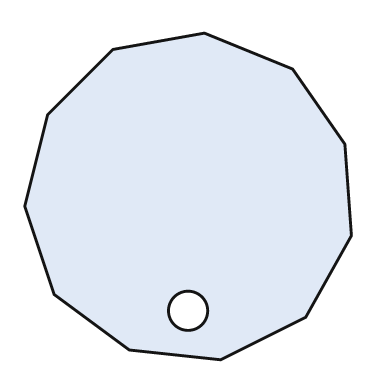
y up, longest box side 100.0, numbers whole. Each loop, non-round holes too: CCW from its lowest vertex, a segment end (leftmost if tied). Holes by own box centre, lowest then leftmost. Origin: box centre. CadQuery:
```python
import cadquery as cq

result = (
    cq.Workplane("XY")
    .moveTo(10.0, -50.0)
    .lineTo(36.0, -37.0)
    .lineTo(50.0, -12.0)
    .lineTo(48.0, 16.0)
    .lineTo(32.0, 39.0)
    .lineTo(5.0, 50.0)
    .lineTo(-23.0, 45.0)
    .lineTo(-43.0, 25.0)
    .lineTo(-50.0, -3.0)
    .lineTo(-41.0, -30.0)
    .lineTo(-18.0, -47.0)
    .close()
    .moveTo(0.0, -35.0)
    .circle(6.0)
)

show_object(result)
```